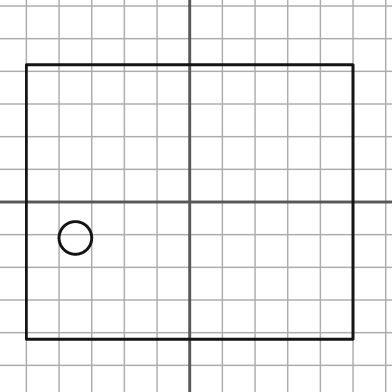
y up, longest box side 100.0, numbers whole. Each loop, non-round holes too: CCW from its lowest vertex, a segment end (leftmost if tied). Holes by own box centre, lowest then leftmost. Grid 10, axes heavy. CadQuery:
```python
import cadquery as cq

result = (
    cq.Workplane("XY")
    .moveTo(-50.0, -42.0)
    .lineTo(50.0, -42.0)
    .lineTo(50.0, 42.0)
    .lineTo(-50.0, 42.0)
    .close()
    .moveTo(-35.0, -11.0)
    .circle(5.0)
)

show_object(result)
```